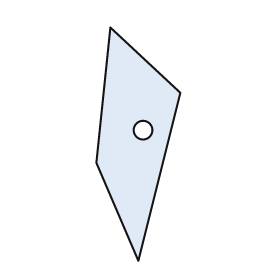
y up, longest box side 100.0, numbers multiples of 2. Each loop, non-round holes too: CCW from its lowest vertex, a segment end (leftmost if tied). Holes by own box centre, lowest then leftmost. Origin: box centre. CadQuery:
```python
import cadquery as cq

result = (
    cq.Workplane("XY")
    .moveTo(0.0, -50.0)
    .lineTo(18.0, 22.0)
    .lineTo(-12.0, 50.0)
    .lineTo(-18.0, -8.0)
    .close()
    .moveTo(2.0, 6.0)
    .circle(4.0)
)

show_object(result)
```